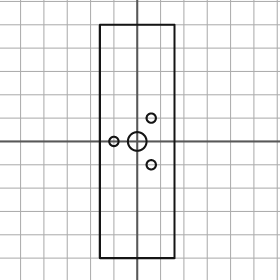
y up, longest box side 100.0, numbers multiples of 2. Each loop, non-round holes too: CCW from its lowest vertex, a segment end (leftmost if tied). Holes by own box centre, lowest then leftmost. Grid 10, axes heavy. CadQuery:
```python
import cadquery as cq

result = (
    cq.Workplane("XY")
    .moveTo(-16.0, -50.0)
    .lineTo(16.0, -50.0)
    .lineTo(16.0, 50.0)
    .lineTo(-16.0, 50.0)
    .close()
    .moveTo(6.0, -10.0)
    .circle(2.0)
    .moveTo(-10.0, 0.0)
    .circle(2.0)
    .moveTo(0.0, 0.0)
    .circle(4.0)
    .moveTo(6.0, 10.0)
    .circle(2.0)
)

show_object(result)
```